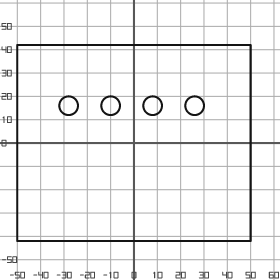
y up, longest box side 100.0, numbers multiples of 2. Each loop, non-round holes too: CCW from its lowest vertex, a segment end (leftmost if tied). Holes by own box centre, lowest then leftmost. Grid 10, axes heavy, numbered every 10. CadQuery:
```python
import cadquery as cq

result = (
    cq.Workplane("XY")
    .moveTo(-50.0, -42.0)
    .lineTo(50.0, -42.0)
    .lineTo(50.0, 42.0)
    .lineTo(-50.0, 42.0)
    .close()
    .moveTo(-28.0, 16.0)
    .circle(4.0)
    .moveTo(-10.0, 16.0)
    .circle(4.0)
    .moveTo(8.0, 16.0)
    .circle(4.0)
    .moveTo(26.0, 16.0)
    .circle(4.0)
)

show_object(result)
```